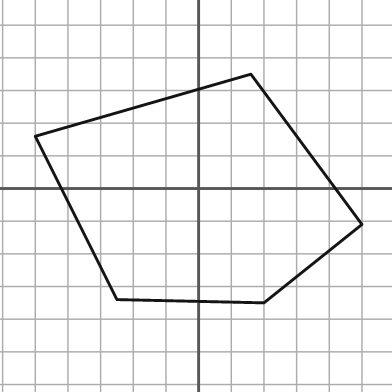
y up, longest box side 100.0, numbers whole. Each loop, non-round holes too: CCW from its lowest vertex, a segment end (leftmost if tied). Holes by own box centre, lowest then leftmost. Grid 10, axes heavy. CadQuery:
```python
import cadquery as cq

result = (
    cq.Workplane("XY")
    .moveTo(20.0, -35.0)
    .lineTo(50.0, -11.0)
    .lineTo(16.0, 35.0)
    .lineTo(-50.0, 16.0)
    .lineTo(-25.0, -34.0)
    .close()
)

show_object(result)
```